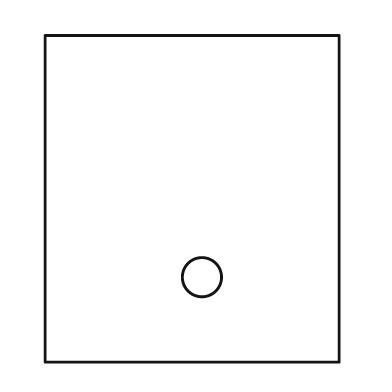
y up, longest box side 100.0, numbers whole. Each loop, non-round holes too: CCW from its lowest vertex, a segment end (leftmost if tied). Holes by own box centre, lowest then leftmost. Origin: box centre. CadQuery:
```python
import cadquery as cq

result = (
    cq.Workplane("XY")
    .moveTo(-45.0, -50.0)
    .lineTo(45.0, -50.0)
    .lineTo(45.0, 50.0)
    .lineTo(-45.0, 50.0)
    .close()
    .moveTo(3.0, -24.0)
    .circle(6.0)
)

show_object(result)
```